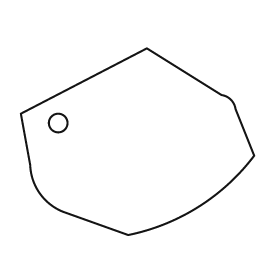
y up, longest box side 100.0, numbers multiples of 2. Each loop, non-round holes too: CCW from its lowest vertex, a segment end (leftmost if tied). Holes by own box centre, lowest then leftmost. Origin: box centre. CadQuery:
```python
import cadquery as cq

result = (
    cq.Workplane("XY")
    .moveTo(-4.0, -40.0)
    .threePointArc((26.0, -28.0), (50.0, -6.0))
    .lineTo(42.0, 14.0)
    .threePointArc((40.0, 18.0), (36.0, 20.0))
    .lineTo(4.0, 40.0)
    .lineTo(-50.0, 12.0)
    .lineTo(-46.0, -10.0)
    .threePointArc((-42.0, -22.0), (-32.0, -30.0))
    .close()
    .moveTo(-34.0, 8.0)
    .circle(4.0)
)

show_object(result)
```